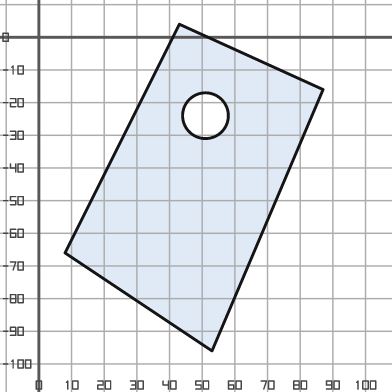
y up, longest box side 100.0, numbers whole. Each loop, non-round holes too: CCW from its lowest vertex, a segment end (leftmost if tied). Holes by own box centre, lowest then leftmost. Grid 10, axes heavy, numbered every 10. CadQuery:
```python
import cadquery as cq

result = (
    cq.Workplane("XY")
    .moveTo(53.0, -96.0)
    .lineTo(87.0, -16.0)
    .lineTo(43.0, 4.0)
    .lineTo(8.0, -66.0)
    .close()
    .moveTo(51.0, -24.0)
    .circle(7.0)
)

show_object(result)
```